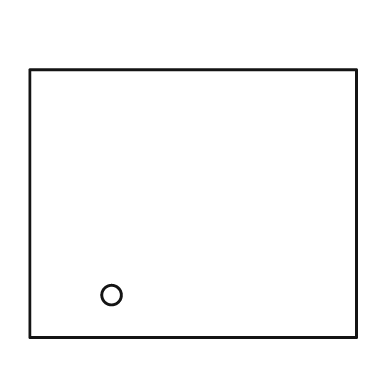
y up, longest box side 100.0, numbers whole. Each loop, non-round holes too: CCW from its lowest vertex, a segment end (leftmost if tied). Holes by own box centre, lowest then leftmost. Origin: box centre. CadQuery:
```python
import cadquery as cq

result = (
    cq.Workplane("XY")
    .moveTo(-50.0, -41.0)
    .lineTo(50.0, -41.0)
    .lineTo(50.0, 41.0)
    .lineTo(-50.0, 41.0)
    .close()
    .moveTo(-25.0, -28.0)
    .circle(3.0)
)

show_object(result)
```